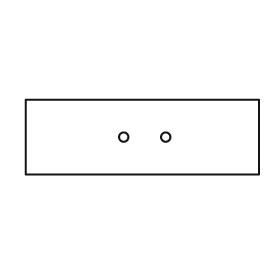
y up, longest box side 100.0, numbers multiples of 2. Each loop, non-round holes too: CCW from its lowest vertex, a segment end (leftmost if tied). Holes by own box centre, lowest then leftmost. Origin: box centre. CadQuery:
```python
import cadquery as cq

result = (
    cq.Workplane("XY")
    .moveTo(-50.0, -16.0)
    .lineTo(50.0, -16.0)
    .lineTo(50.0, 16.0)
    .lineTo(-50.0, 16.0)
    .close()
    .moveTo(-8.0, 0.0)
    .circle(2.0)
    .moveTo(10.0, 0.0)
    .circle(2.0)
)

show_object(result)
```